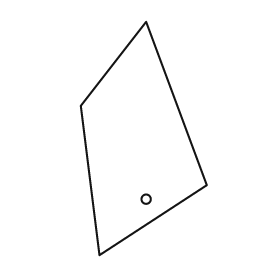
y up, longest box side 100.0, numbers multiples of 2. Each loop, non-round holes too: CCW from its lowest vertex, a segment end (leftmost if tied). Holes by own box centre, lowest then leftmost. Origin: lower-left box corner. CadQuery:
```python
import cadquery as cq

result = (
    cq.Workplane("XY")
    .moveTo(8.0, 0.0)
    .lineTo(54.0, 30.0)
    .lineTo(28.0, 100.0)
    .lineTo(0.0, 64.0)
    .close()
    .moveTo(28.0, 24.0)
    .circle(2.0)
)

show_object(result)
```